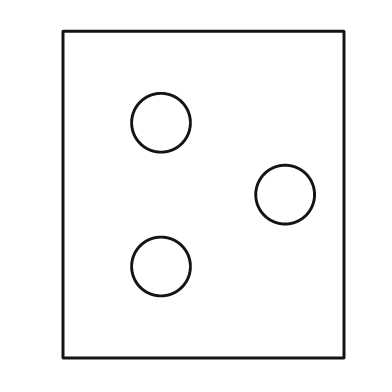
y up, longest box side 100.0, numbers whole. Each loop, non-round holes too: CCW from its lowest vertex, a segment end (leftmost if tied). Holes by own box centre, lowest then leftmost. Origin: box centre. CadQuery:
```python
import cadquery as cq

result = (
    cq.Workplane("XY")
    .moveTo(-43.0, -50.0)
    .lineTo(43.0, -50.0)
    .lineTo(43.0, 50.0)
    .lineTo(-43.0, 50.0)
    .close()
    .moveTo(-13.0, -22.0)
    .circle(9.0)
    .moveTo(25.0, 0.0)
    .circle(9.0)
    .moveTo(-13.0, 22.0)
    .circle(9.0)
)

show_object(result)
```